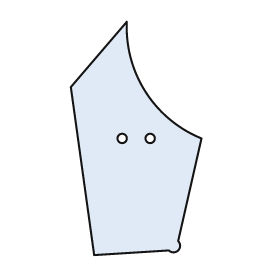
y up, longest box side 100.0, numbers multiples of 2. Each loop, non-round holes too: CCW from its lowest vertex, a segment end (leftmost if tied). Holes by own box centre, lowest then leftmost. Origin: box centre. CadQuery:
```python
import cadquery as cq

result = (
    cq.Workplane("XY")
    .moveTo(-18.0, -50.0)
    .lineTo(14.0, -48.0)
    .threePointArc((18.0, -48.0), (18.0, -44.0))
    .lineTo(28.0, 0.0)
    .threePointArc((4.0, 20.0), (-4.0, 50.0))
    .lineTo(-28.0, 22.0)
    .close()
    .moveTo(-6.0, 0.0)
    .circle(2.0)
    .moveTo(6.0, 0.0)
    .circle(2.0)
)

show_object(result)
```